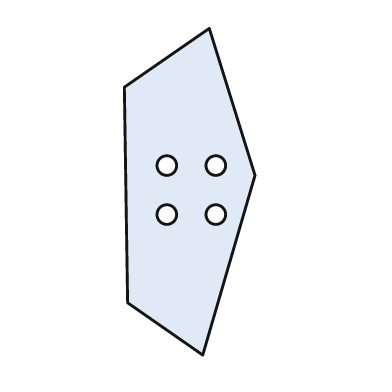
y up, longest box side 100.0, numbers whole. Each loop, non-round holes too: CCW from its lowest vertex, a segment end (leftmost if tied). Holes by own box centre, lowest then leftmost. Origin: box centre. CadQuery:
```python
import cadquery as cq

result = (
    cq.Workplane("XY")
    .moveTo(4.0, -50.0)
    .lineTo(20.0, 5.0)
    .lineTo(6.0, 50.0)
    .lineTo(-20.0, 32.0)
    .lineTo(-19.0, -34.0)
    .close()
    .moveTo(-7.0, -7.0)
    .circle(3.0)
    .moveTo(8.0, -7.0)
    .circle(3.0)
    .moveTo(-7.0, 8.0)
    .circle(3.0)
    .moveTo(8.0, 8.0)
    .circle(3.0)
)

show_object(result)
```